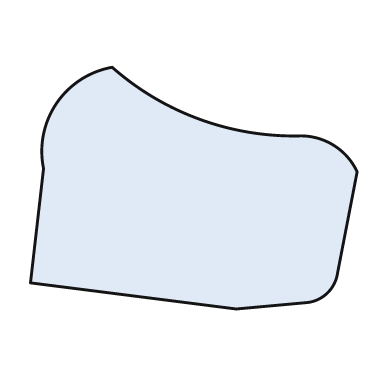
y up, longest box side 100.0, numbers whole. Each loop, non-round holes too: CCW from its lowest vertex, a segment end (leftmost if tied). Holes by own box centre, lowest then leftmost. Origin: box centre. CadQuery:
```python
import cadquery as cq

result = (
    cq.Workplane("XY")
    .moveTo(13.0, -37.0)
    .lineTo(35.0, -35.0)
    .threePointArc((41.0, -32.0), (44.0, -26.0))
    .lineTo(50.0, 5.0)
    .threePointArc((43.0, 13.0), (33.0, 16.0))
    .threePointArc((2.0, 21.0), (-25.0, 37.0))
    .threePointArc((-42.0, 26.0), (-46.0, 6.0))
    .lineTo(-50.0, -29.0)
    .close()
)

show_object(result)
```